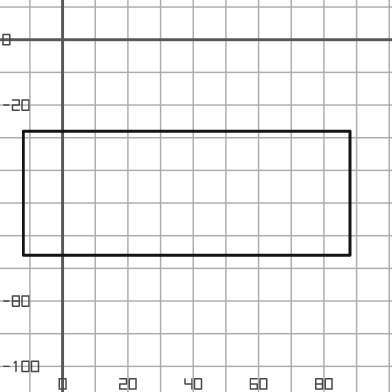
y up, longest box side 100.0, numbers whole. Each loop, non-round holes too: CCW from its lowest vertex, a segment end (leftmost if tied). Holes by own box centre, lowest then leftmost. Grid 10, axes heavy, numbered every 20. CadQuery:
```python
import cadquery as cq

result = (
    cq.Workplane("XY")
    .moveTo(-12.0, -66.0)
    .lineTo(88.0, -66.0)
    .lineTo(88.0, -28.0)
    .lineTo(-12.0, -28.0)
    .close()
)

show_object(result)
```